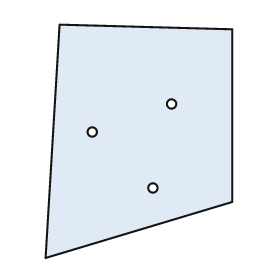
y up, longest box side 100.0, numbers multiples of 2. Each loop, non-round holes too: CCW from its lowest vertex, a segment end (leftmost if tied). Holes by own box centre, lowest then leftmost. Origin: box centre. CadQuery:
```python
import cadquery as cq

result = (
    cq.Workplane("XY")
    .moveTo(-40.0, -50.0)
    .lineTo(40.0, -26.0)
    .lineTo(40.0, 48.0)
    .lineTo(-34.0, 50.0)
    .close()
    .moveTo(6.0, -20.0)
    .circle(2.0)
    .moveTo(-20.0, 4.0)
    .circle(2.0)
    .moveTo(14.0, 16.0)
    .circle(2.0)
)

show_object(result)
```